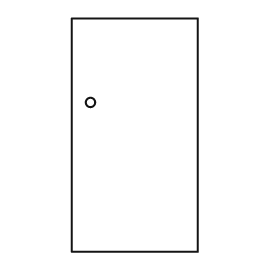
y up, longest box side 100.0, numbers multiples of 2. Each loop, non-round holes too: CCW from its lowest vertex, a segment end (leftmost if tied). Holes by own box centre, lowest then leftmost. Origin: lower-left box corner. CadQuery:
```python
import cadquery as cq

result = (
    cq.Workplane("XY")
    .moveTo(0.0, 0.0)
    .lineTo(54.0, 0.0)
    .lineTo(54.0, 100.0)
    .lineTo(0.0, 100.0)
    .close()
    .moveTo(8.0, 64.0)
    .circle(2.0)
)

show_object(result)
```